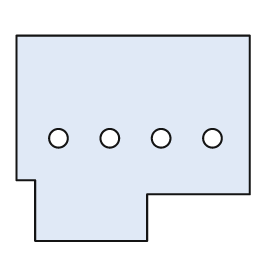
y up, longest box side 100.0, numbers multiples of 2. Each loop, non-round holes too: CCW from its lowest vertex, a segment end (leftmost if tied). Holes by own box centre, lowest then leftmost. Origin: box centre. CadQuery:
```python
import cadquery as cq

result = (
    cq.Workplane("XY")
    .moveTo(-42.0, -44.0)
    .lineTo(6.0, -44.0)
    .lineTo(6.0, -24.0)
    .lineTo(50.0, -24.0)
    .lineTo(50.0, 44.0)
    .lineTo(-50.0, 44.0)
    .lineTo(-50.0, -18.0)
    .lineTo(-42.0, -18.0)
    .close()
    .moveTo(-32.0, 0.0)
    .circle(4.0)
    .moveTo(-10.0, 0.0)
    .circle(4.0)
    .moveTo(12.0, 0.0)
    .circle(4.0)
    .moveTo(34.0, 0.0)
    .circle(4.0)
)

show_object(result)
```